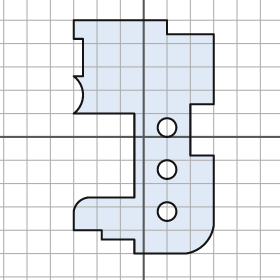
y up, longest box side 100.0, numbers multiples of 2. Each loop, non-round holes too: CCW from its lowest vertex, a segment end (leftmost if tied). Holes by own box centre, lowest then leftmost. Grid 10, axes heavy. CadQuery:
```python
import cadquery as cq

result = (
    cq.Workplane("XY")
    .moveTo(-4.0, -50.0)
    .lineTo(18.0, -50.0)
    .threePointArc((26.0, -46.0), (30.0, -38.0))
    .lineTo(30.0, -8.0)
    .lineTo(20.0, -8.0)
    .lineTo(20.0, 14.0)
    .lineTo(30.0, 14.0)
    .lineTo(30.0, 44.0)
    .lineTo(10.0, 44.0)
    .lineTo(10.0, 50.0)
    .lineTo(-30.0, 50.0)
    .lineTo(-30.0, 42.0)
    .lineTo(-26.0, 42.0)
    .lineTo(-26.0, 26.0)
    .lineTo(-30.0, 26.0)
    .threePointArc((-26.0, 18.0), (-30.0, 10.0))
    .lineTo(-4.0, 10.0)
    .lineTo(-4.0, -26.0)
    .lineTo(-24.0, -26.0)
    .threePointArc((-28.0, -28.0), (-30.0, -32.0))
    .lineTo(-30.0, -40.0)
    .lineTo(-18.0, -40.0)
    .lineTo(-18.0, -44.0)
    .lineTo(-4.0, -44.0)
    .close()
    .moveTo(10.0, -32.0)
    .circle(4.0)
    .moveTo(10.0, -14.0)
    .circle(4.0)
    .moveTo(10.0, 4.0)
    .circle(4.0)
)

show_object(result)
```